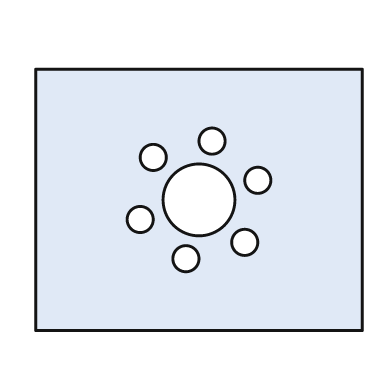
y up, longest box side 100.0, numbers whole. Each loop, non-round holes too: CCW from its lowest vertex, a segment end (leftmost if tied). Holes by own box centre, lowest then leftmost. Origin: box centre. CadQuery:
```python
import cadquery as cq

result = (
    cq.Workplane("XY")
    .moveTo(-50.0, -40.0)
    .lineTo(50.0, -40.0)
    .lineTo(50.0, 40.0)
    .lineTo(-50.0, 40.0)
    .close()
    .moveTo(-4.0, -18.0)
    .circle(4.0)
    .moveTo(14.0, -13.0)
    .circle(4.0)
    .moveTo(-18.0, -6.0)
    .circle(4.0)
    .moveTo(0.0, 0.0)
    .circle(11.0)
    .moveTo(18.0, 6.0)
    .circle(4.0)
    .moveTo(-14.0, 13.0)
    .circle(4.0)
    .moveTo(4.0, 18.0)
    .circle(4.0)
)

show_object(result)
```